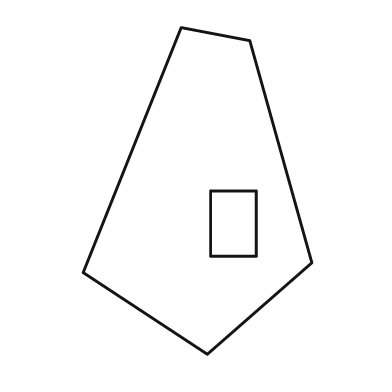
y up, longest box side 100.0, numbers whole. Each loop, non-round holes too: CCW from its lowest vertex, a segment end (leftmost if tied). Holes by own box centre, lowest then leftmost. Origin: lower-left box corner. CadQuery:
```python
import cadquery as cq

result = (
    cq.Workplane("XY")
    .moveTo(38.0, 0.0)
    .lineTo(70.0, 28.0)
    .lineTo(51.0, 96.0)
    .lineTo(30.0, 100.0)
    .lineTo(0.0, 25.0)
    .close()
    .moveTo(39.0, 30.0)
    .lineTo(53.0, 30.0)
    .lineTo(53.0, 50.0)
    .lineTo(39.0, 50.0)
    .close()
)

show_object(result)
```